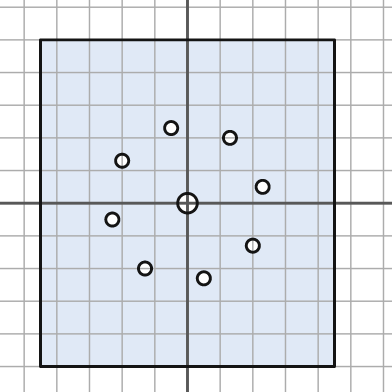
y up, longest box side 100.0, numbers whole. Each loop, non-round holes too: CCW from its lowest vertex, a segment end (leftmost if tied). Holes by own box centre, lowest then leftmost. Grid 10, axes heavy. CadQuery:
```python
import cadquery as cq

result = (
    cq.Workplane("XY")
    .moveTo(-45.0, -50.0)
    .lineTo(45.0, -50.0)
    .lineTo(45.0, 50.0)
    .lineTo(-45.0, 50.0)
    .close()
    .moveTo(5.0, -23.0)
    .circle(2.0)
    .moveTo(-13.0, -20.0)
    .circle(2.0)
    .moveTo(20.0, -13.0)
    .circle(2.0)
    .moveTo(-23.0, -5.0)
    .circle(2.0)
    .moveTo(0.0, 0.0)
    .circle(3.0)
    .moveTo(23.0, 5.0)
    .circle(2.0)
    .moveTo(-20.0, 13.0)
    .circle(2.0)
    .moveTo(13.0, 20.0)
    .circle(2.0)
    .moveTo(-5.0, 23.0)
    .circle(2.0)
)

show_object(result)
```